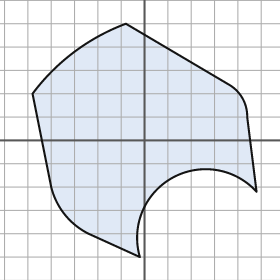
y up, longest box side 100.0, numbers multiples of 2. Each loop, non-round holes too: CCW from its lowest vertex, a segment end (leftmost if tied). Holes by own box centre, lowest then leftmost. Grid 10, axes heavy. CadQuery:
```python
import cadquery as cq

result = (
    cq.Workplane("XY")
    .moveTo(-2.0, -50.0)
    .threePointArc((12.0, -16.0), (48.0, -22.0))
    .lineTo(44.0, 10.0)
    .threePointArc((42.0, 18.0), (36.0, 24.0))
    .lineTo(-8.0, 50.0)
    .threePointArc((-30.0, 38.0), (-48.0, 20.0))
    .lineTo(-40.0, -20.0)
    .threePointArc((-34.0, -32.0), (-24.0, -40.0))
    .close()
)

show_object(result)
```